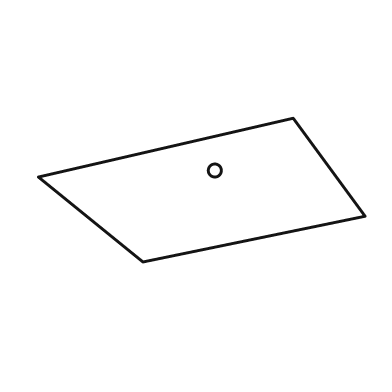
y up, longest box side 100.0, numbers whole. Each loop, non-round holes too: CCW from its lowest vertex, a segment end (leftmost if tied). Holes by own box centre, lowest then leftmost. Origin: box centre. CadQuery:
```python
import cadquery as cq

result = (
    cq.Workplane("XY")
    .moveTo(-18.0, -22.0)
    .lineTo(50.0, -8.0)
    .lineTo(28.0, 22.0)
    .lineTo(-50.0, 4.0)
    .close()
    .moveTo(4.0, 6.0)
    .circle(2.0)
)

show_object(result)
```